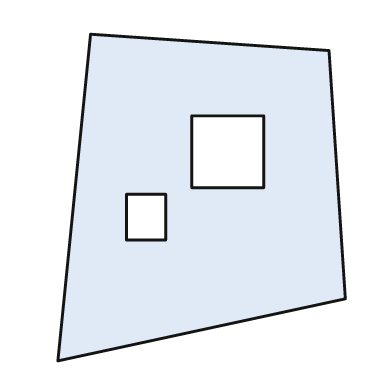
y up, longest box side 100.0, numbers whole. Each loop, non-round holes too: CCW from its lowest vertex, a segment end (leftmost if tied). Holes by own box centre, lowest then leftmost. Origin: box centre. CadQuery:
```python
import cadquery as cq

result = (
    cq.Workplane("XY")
    .moveTo(-44.0, -50.0)
    .lineTo(44.0, -31.0)
    .lineTo(39.0, 45.0)
    .lineTo(-34.0, 50.0)
    .close()
    .moveTo(-23.0, -13.0)
    .lineTo(-11.0, -13.0)
    .lineTo(-11.0, 1.0)
    .lineTo(-23.0, 1.0)
    .close()
    .moveTo(-3.0, 3.0)
    .lineTo(19.0, 3.0)
    .lineTo(19.0, 25.0)
    .lineTo(-3.0, 25.0)
    .close()
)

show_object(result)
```